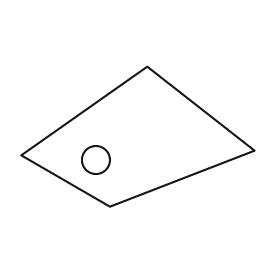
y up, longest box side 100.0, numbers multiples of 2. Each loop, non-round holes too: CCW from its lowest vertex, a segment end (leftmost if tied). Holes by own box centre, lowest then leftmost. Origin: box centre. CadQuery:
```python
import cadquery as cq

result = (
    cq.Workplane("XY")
    .moveTo(-12.0, -30.0)
    .lineTo(50.0, -6.0)
    .lineTo(4.0, 30.0)
    .lineTo(-50.0, -8.0)
    .close()
    .moveTo(-18.0, -10.0)
    .circle(6.0)
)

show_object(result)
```